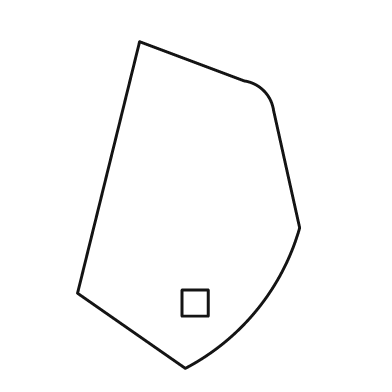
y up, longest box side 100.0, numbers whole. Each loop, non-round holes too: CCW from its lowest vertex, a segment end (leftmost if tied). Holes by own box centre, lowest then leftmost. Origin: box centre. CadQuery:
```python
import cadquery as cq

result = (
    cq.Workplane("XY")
    .moveTo(-1.0, -50.0)
    .threePointArc((21.0, -32.0), (34.0, -7.0))
    .lineTo(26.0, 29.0)
    .threePointArc((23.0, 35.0), (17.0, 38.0))
    .lineTo(-15.0, 50.0)
    .lineTo(-34.0, -27.0)
    .close()
    .moveTo(-2.0, -34.0)
    .lineTo(6.0, -34.0)
    .lineTo(6.0, -26.0)
    .lineTo(-2.0, -26.0)
    .close()
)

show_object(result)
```